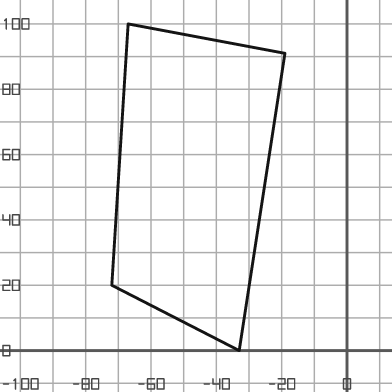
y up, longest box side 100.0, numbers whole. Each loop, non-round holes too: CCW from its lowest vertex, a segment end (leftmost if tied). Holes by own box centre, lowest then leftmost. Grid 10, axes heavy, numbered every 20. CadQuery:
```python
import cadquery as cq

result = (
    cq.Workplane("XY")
    .moveTo(-33.0, 0.0)
    .lineTo(-19.0, 91.0)
    .lineTo(-67.0, 100.0)
    .lineTo(-72.0, 20.0)
    .close()
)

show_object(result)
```